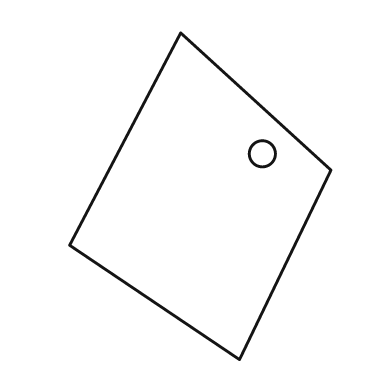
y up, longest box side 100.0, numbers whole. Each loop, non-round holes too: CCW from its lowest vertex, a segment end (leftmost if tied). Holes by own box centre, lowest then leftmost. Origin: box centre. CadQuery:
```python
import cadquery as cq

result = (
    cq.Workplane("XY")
    .moveTo(12.0, -50.0)
    .lineTo(40.0, 8.0)
    .lineTo(-6.0, 50.0)
    .lineTo(-40.0, -15.0)
    .close()
    .moveTo(19.0, 13.0)
    .circle(4.0)
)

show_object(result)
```